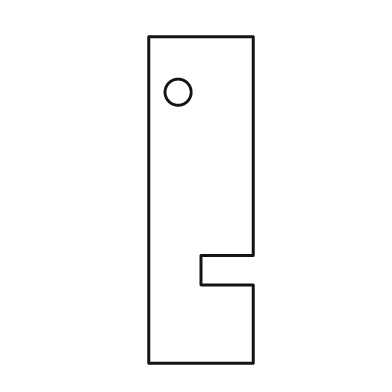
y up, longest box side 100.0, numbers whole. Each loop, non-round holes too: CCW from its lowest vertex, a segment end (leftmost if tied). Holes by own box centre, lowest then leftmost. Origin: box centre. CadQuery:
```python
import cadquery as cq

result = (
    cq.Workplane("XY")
    .moveTo(-16.0, -50.0)
    .lineTo(16.0, -50.0)
    .lineTo(16.0, -26.0)
    .lineTo(0.0, -26.0)
    .lineTo(0.0, -17.0)
    .lineTo(16.0, -17.0)
    .lineTo(16.0, 50.0)
    .lineTo(-16.0, 50.0)
    .close()
    .moveTo(-7.0, 33.0)
    .circle(4.0)
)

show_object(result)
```